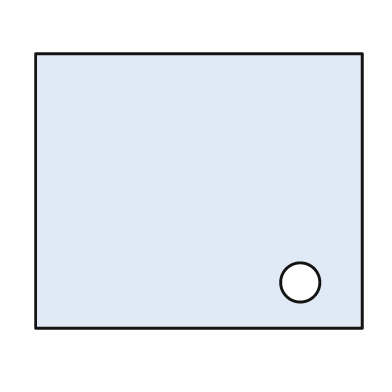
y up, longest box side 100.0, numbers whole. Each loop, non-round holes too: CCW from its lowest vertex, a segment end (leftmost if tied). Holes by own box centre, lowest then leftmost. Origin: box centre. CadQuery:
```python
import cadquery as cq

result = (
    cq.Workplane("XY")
    .moveTo(-50.0, -42.0)
    .lineTo(50.0, -42.0)
    .lineTo(50.0, 42.0)
    .lineTo(-50.0, 42.0)
    .close()
    .moveTo(31.0, -28.0)
    .circle(6.0)
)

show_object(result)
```